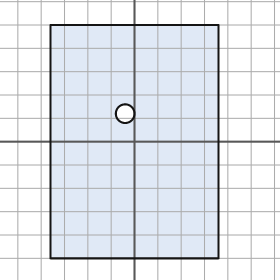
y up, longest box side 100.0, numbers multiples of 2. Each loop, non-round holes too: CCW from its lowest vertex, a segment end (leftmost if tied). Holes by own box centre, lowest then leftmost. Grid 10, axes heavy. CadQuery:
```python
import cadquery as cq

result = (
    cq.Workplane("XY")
    .moveTo(-36.0, -50.0)
    .lineTo(36.0, -50.0)
    .lineTo(36.0, 50.0)
    .lineTo(-36.0, 50.0)
    .close()
    .moveTo(-4.0, 12.0)
    .circle(4.0)
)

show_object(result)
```